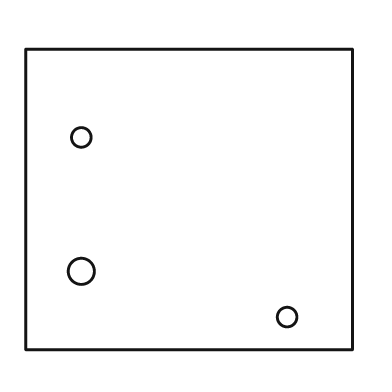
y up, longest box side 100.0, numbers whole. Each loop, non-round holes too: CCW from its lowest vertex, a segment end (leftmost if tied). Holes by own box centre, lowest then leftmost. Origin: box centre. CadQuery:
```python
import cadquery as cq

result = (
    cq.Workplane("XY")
    .moveTo(-50.0, -46.0)
    .lineTo(50.0, -46.0)
    .lineTo(50.0, 46.0)
    .lineTo(-50.0, 46.0)
    .close()
    .moveTo(30.0, -36.0)
    .circle(3.0)
    .moveTo(-33.0, -22.0)
    .circle(4.0)
    .moveTo(-33.0, 19.0)
    .circle(3.0)
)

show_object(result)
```